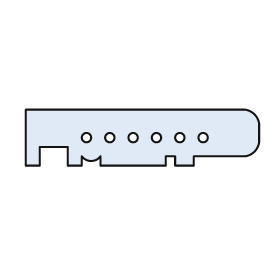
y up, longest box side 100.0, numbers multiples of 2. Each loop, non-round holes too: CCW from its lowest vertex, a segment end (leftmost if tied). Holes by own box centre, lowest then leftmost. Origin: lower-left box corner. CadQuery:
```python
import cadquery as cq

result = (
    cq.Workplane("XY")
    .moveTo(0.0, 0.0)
    .lineTo(6.0, 0.0)
    .lineTo(6.0, 8.0)
    .lineTo(18.0, 8.0)
    .lineTo(18.0, 0.0)
    .lineTo(24.0, 0.0)
    .lineTo(24.0, 4.0)
    .threePointArc((28.0, 2.0), (32.0, 4.0))
    .lineTo(32.0, 0.0)
    .lineTo(60.0, 0.0)
    .lineTo(60.0, 4.0)
    .lineTo(64.0, 4.0)
    .lineTo(64.0, 0.0)
    .lineTo(72.0, 0.0)
    .lineTo(72.0, 4.0)
    .lineTo(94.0, 4.0)
    .threePointArc((98.0, 6.0), (100.0, 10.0))
    .lineTo(100.0, 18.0)
    .threePointArc((98.0, 22.0), (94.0, 24.0))
    .lineTo(0.0, 24.0)
    .close()
    .moveTo(26.0, 12.0)
    .circle(2.0)
    .moveTo(36.0, 12.0)
    .circle(2.0)
    .moveTo(46.0, 12.0)
    .circle(2.0)
    .moveTo(56.0, 12.0)
    .circle(2.0)
    .moveTo(66.0, 12.0)
    .circle(2.0)
    .moveTo(76.0, 12.0)
    .circle(2.0)
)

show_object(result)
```